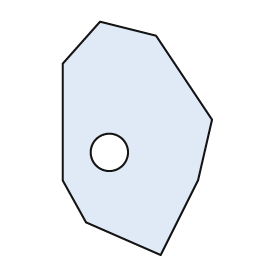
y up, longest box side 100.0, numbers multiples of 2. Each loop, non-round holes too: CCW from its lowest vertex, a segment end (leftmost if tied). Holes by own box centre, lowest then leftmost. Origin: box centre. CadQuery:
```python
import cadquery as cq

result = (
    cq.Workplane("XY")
    .moveTo(10.0, -50.0)
    .lineTo(26.0, -18.0)
    .lineTo(32.0, 8.0)
    .lineTo(8.0, 44.0)
    .lineTo(-16.0, 50.0)
    .lineTo(-32.0, 32.0)
    .lineTo(-32.0, -18.0)
    .lineTo(-22.0, -36.0)
    .close()
    .moveTo(-12.0, -6.0)
    .circle(8.0)
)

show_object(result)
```